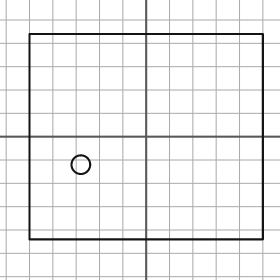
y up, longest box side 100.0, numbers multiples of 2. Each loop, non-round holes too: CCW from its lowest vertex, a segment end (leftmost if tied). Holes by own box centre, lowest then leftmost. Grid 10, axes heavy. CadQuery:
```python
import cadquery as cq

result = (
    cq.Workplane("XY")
    .moveTo(-50.0, -44.0)
    .lineTo(50.0, -44.0)
    .lineTo(50.0, 44.0)
    .lineTo(-50.0, 44.0)
    .close()
    .moveTo(-28.0, -12.0)
    .circle(4.0)
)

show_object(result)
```